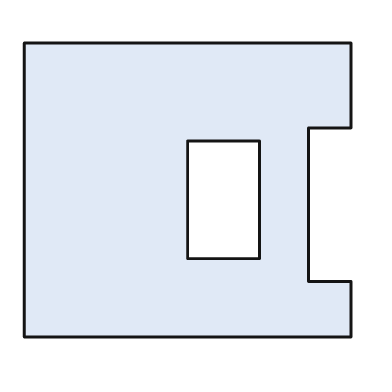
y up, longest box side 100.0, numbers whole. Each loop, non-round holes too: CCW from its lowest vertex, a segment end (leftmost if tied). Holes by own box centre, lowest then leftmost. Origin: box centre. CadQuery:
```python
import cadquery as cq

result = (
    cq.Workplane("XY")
    .moveTo(-50.0, -45.0)
    .lineTo(50.0, -45.0)
    .lineTo(50.0, -28.0)
    .lineTo(37.0, -28.0)
    .lineTo(37.0, 19.0)
    .lineTo(50.0, 19.0)
    .lineTo(50.0, 45.0)
    .lineTo(-50.0, 45.0)
    .close()
    .moveTo(0.0, -21.0)
    .lineTo(22.0, -21.0)
    .lineTo(22.0, 15.0)
    .lineTo(0.0, 15.0)
    .close()
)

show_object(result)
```